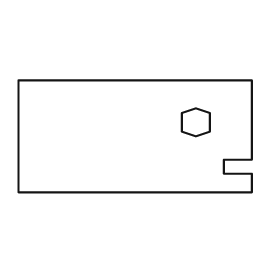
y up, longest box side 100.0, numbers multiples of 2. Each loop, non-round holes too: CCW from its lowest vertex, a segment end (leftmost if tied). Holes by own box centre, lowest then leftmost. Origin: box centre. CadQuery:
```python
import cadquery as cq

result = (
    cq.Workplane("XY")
    .moveTo(-50.0, -24.0)
    .lineTo(50.0, -24.0)
    .lineTo(50.0, -16.0)
    .lineTo(38.0, -16.0)
    .lineTo(38.0, -10.0)
    .lineTo(50.0, -10.0)
    .lineTo(50.0, 24.0)
    .lineTo(-50.0, 24.0)
    .close()
    .moveTo(26.0, 0.0)
    .lineTo(32.0, 2.0)
    .lineTo(32.0, 10.0)
    .lineTo(26.0, 12.0)
    .lineTo(20.0, 10.0)
    .lineTo(20.0, 2.0)
    .close()
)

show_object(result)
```